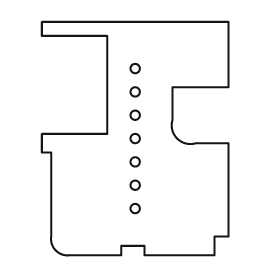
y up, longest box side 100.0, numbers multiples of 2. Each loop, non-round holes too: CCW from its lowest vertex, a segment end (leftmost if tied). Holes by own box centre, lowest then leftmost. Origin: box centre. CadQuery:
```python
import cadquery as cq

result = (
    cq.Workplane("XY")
    .moveTo(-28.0, -50.0)
    .lineTo(-6.0, -50.0)
    .lineTo(-6.0, -46.0)
    .lineTo(4.0, -46.0)
    .lineTo(4.0, -50.0)
    .lineTo(34.0, -50.0)
    .lineTo(34.0, -42.0)
    .lineTo(40.0, -42.0)
    .lineTo(40.0, -2.0)
    .lineTo(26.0, -2.0)
    .threePointArc((18.0, 0.0), (16.0, 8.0))
    .lineTo(16.0, 22.0)
    .lineTo(40.0, 22.0)
    .lineTo(40.0, 50.0)
    .lineTo(-40.0, 50.0)
    .lineTo(-40.0, 44.0)
    .lineTo(-12.0, 44.0)
    .lineTo(-12.0, 2.0)
    .lineTo(-40.0, 2.0)
    .lineTo(-40.0, -6.0)
    .lineTo(-36.0, -6.0)
    .lineTo(-36.0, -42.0)
    .threePointArc((-34.0, -48.0), (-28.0, -50.0))
    .close()
    .moveTo(0.0, -30.0)
    .circle(2.0)
    .moveTo(0.0, -20.0)
    .circle(2.0)
    .moveTo(0.0, -10.0)
    .circle(2.0)
    .moveTo(0.0, 0.0)
    .circle(2.0)
    .moveTo(0.0, 10.0)
    .circle(2.0)
    .moveTo(0.0, 20.0)
    .circle(2.0)
    .moveTo(0.0, 30.0)
    .circle(2.0)
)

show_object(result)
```